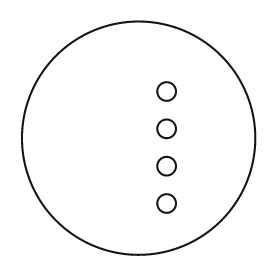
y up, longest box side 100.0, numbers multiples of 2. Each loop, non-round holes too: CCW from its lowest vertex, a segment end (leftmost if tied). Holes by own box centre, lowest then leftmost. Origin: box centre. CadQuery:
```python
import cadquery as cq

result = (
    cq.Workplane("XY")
    .moveTo(0.0, 0.0)
    .circle(50.0)
    .moveTo(12.0, -28.0)
    .circle(4.0)
    .moveTo(12.0, -12.0)
    .circle(4.0)
    .moveTo(12.0, 4.0)
    .circle(4.0)
    .moveTo(12.0, 20.0)
    .circle(4.0)
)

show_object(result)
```